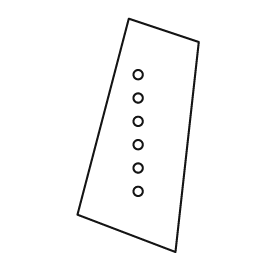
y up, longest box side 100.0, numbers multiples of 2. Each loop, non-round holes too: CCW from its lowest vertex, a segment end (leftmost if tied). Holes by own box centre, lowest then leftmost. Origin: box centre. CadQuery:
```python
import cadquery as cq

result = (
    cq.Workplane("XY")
    .moveTo(16.0, -50.0)
    .lineTo(26.0, 40.0)
    .lineTo(-4.0, 50.0)
    .lineTo(-26.0, -34.0)
    .close()
    .moveTo(0.0, -24.0)
    .circle(2.0)
    .moveTo(0.0, -14.0)
    .circle(2.0)
    .moveTo(0.0, -4.0)
    .circle(2.0)
    .moveTo(0.0, 6.0)
    .circle(2.0)
    .moveTo(0.0, 16.0)
    .circle(2.0)
    .moveTo(0.0, 26.0)
    .circle(2.0)
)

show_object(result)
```